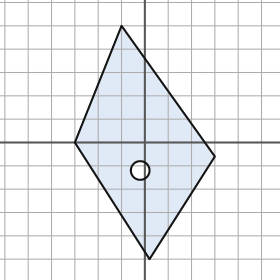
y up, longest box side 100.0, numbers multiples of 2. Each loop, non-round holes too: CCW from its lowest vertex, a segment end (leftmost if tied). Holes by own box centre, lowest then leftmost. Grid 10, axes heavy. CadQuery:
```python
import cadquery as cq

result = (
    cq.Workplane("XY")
    .moveTo(2.0, -50.0)
    .lineTo(30.0, -6.0)
    .lineTo(-10.0, 50.0)
    .lineTo(-30.0, 0.0)
    .close()
    .moveTo(-2.0, -12.0)
    .circle(4.0)
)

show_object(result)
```